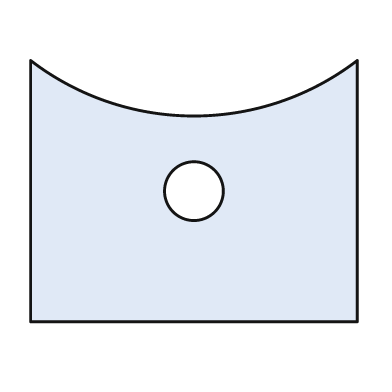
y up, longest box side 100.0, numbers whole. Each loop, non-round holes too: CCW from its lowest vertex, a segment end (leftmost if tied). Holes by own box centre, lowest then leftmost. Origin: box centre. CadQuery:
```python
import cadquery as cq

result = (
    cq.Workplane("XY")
    .moveTo(-50.0, -40.0)
    .lineTo(50.0, -40.0)
    .lineTo(50.0, 40.0)
    .threePointArc((0.0, 23.0), (-50.0, 40.0))
    .close()
    .moveTo(0.0, 0.0)
    .circle(9.0)
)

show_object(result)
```